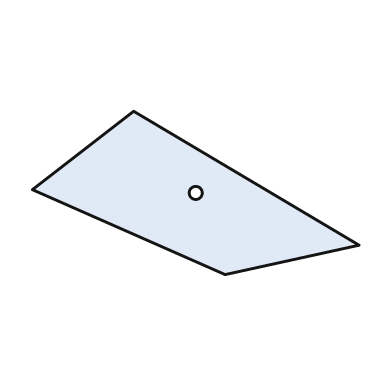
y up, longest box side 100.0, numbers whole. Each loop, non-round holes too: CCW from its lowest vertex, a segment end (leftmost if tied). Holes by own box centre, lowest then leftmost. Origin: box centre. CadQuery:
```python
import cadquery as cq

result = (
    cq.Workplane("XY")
    .moveTo(9.0, -25.0)
    .lineTo(50.0, -16.0)
    .lineTo(-19.0, 25.0)
    .lineTo(-50.0, 1.0)
    .close()
    .moveTo(0.0, 0.0)
    .circle(2.0)
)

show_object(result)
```